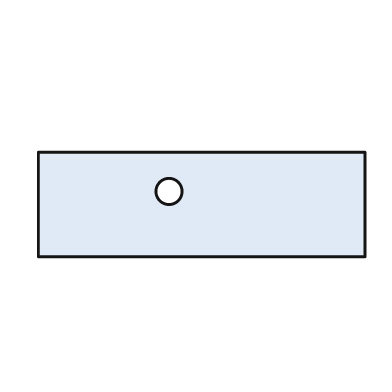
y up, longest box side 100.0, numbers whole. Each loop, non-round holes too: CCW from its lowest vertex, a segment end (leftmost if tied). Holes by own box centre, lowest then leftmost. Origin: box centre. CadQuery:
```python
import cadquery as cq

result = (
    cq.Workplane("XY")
    .moveTo(-50.0, -16.0)
    .lineTo(50.0, -16.0)
    .lineTo(50.0, 16.0)
    .lineTo(-50.0, 16.0)
    .close()
    .moveTo(-10.0, 4.0)
    .circle(4.0)
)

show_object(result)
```